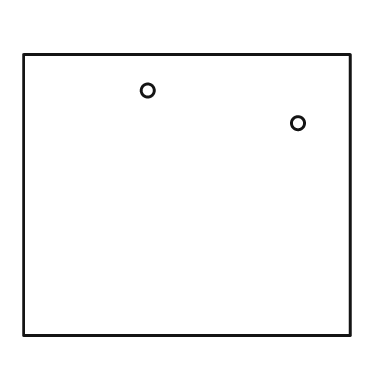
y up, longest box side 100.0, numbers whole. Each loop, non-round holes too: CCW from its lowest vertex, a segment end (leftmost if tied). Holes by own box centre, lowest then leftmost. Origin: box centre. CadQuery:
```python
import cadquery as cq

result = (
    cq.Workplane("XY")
    .moveTo(-50.0, -43.0)
    .lineTo(50.0, -43.0)
    .lineTo(50.0, 43.0)
    .lineTo(-50.0, 43.0)
    .close()
    .moveTo(34.0, 22.0)
    .circle(2.0)
    .moveTo(-12.0, 32.0)
    .circle(2.0)
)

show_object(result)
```